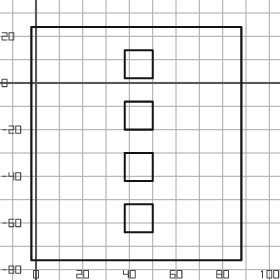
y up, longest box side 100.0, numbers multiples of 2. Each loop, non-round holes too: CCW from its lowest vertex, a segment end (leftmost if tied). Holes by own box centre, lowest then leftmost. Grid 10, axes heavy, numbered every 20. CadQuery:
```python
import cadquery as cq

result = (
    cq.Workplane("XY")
    .moveTo(-2.0, -76.0)
    .lineTo(88.0, -76.0)
    .lineTo(88.0, 24.0)
    .lineTo(-2.0, 24.0)
    .close()
    .moveTo(38.0, -64.0)
    .lineTo(50.0, -64.0)
    .lineTo(50.0, -52.0)
    .lineTo(38.0, -52.0)
    .close()
    .moveTo(38.0, -42.0)
    .lineTo(50.0, -42.0)
    .lineTo(50.0, -30.0)
    .lineTo(38.0, -30.0)
    .close()
    .moveTo(38.0, -20.0)
    .lineTo(50.0, -20.0)
    .lineTo(50.0, -8.0)
    .lineTo(38.0, -8.0)
    .close()
    .moveTo(38.0, 2.0)
    .lineTo(50.0, 2.0)
    .lineTo(50.0, 14.0)
    .lineTo(38.0, 14.0)
    .close()
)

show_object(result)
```